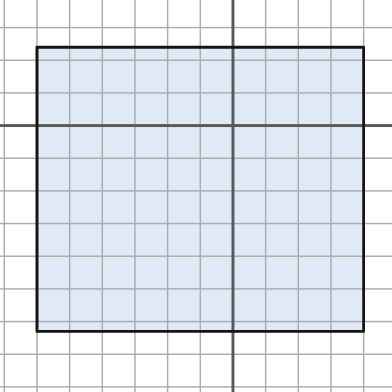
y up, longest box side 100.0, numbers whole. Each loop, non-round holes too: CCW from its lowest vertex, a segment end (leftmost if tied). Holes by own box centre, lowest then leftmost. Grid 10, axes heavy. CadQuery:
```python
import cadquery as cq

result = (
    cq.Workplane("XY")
    .moveTo(-60.0, -63.0)
    .lineTo(40.0, -63.0)
    .lineTo(40.0, 24.0)
    .lineTo(-60.0, 24.0)
    .close()
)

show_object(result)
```